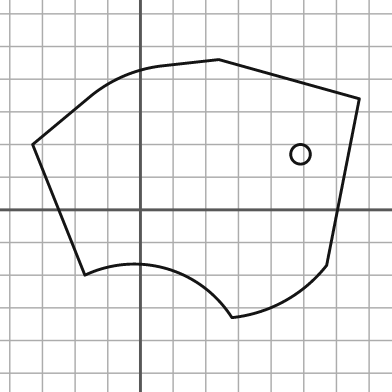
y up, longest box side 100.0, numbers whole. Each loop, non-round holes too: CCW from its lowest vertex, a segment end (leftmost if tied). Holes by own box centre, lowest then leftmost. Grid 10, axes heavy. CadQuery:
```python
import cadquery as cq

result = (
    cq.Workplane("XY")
    .moveTo(28.0, -33.0)
    .threePointArc((44.0, -28.0), (57.0, -17.0))
    .lineTo(67.0, 34.0)
    .lineTo(24.0, 46.0)
    .lineTo(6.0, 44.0)
    .threePointArc((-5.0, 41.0), (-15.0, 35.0))
    .lineTo(-33.0, 20.0)
    .lineTo(-17.0, -20.0)
    .threePointArc((8.0, -18.0), (28.0, -33.0))
    .close()
    .moveTo(49.0, 17.0)
    .circle(3.0)
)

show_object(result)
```